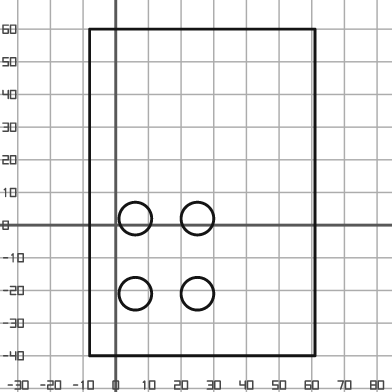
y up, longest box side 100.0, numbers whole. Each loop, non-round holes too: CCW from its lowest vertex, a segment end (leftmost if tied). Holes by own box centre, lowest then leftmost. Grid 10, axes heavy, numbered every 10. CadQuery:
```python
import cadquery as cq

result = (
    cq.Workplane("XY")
    .moveTo(-8.0, -40.0)
    .lineTo(61.0, -40.0)
    .lineTo(61.0, 60.0)
    .lineTo(-8.0, 60.0)
    .close()
    .moveTo(6.0, -21.0)
    .circle(5.0)
    .moveTo(25.0, -21.0)
    .circle(5.0)
    .moveTo(6.0, 2.0)
    .circle(5.0)
    .moveTo(25.0, 2.0)
    .circle(5.0)
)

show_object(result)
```